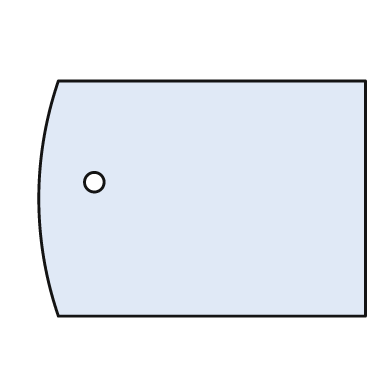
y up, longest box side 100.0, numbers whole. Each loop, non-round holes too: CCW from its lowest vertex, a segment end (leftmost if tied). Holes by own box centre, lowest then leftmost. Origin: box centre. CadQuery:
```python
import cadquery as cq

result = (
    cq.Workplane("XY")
    .moveTo(-44.0, -36.0)
    .lineTo(50.0, -36.0)
    .lineTo(50.0, 36.0)
    .lineTo(-44.0, 36.0)
    .threePointArc((-50.0, 0.0), (-44.0, -36.0))
    .close()
    .moveTo(-33.0, 5.0)
    .circle(3.0)
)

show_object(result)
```